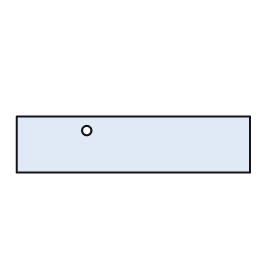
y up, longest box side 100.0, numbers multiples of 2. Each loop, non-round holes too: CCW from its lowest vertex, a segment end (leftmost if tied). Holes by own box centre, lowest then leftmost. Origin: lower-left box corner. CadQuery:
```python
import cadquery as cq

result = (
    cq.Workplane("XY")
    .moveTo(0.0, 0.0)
    .lineTo(100.0, 0.0)
    .lineTo(100.0, 24.0)
    .lineTo(0.0, 24.0)
    .close()
    .moveTo(30.0, 18.0)
    .circle(2.0)
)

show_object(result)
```